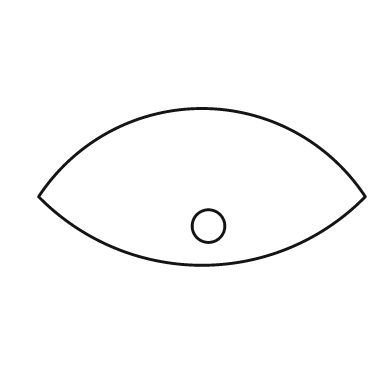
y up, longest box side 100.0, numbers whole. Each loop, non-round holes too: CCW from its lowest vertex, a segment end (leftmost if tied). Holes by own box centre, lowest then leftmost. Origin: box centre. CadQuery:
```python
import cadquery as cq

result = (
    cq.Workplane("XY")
    .moveTo(-50.0, -3.0)
    .threePointArc((0.0, -24.0), (50.0, -3.0))
    .threePointArc((0.0, 24.0), (-50.0, -3.0))
    .close()
    .moveTo(2.0, -12.0)
    .circle(5.0)
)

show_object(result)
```